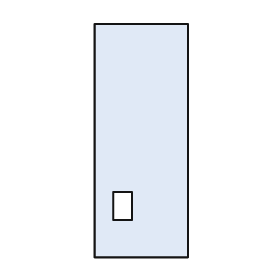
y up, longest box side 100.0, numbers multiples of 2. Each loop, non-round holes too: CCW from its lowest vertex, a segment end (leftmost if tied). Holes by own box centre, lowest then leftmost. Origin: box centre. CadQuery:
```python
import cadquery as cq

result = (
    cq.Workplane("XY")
    .moveTo(-20.0, -50.0)
    .lineTo(20.0, -50.0)
    .lineTo(20.0, 50.0)
    .lineTo(-20.0, 50.0)
    .close()
    .moveTo(-12.0, -34.0)
    .lineTo(-4.0, -34.0)
    .lineTo(-4.0, -22.0)
    .lineTo(-12.0, -22.0)
    .close()
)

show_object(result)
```